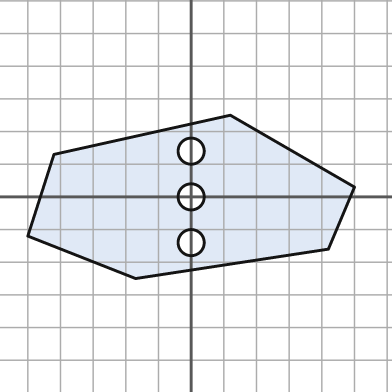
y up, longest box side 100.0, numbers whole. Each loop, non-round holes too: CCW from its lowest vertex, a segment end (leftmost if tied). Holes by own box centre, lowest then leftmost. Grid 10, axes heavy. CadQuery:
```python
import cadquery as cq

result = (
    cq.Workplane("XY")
    .moveTo(-17.0, -25.0)
    .lineTo(42.0, -16.0)
    .lineTo(50.0, 3.0)
    .lineTo(12.0, 25.0)
    .lineTo(-42.0, 13.0)
    .lineTo(-50.0, -12.0)
    .close()
    .moveTo(0.0, -14.0)
    .circle(4.0)
    .moveTo(0.0, 0.0)
    .circle(4.0)
    .moveTo(0.0, 14.0)
    .circle(4.0)
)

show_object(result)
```